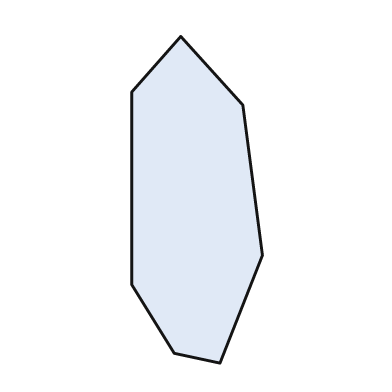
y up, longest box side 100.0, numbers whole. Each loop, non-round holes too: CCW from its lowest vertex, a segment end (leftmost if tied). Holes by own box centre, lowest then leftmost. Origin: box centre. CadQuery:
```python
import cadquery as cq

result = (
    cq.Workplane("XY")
    .moveTo(7.0, -50.0)
    .lineTo(20.0, -17.0)
    .lineTo(14.0, 29.0)
    .lineTo(-5.0, 50.0)
    .lineTo(-20.0, 33.0)
    .lineTo(-20.0, -26.0)
    .lineTo(-7.0, -47.0)
    .close()
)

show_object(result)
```